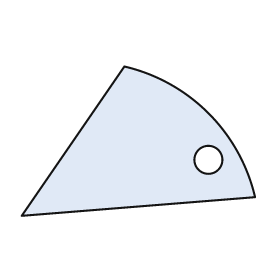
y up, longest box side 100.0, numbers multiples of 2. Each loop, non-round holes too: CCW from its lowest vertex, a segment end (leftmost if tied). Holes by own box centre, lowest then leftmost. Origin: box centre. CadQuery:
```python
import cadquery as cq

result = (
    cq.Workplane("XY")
    .moveTo(-50.0, -32.0)
    .lineTo(50.0, -24.0)
    .threePointArc((30.0, 12.0), (-6.0, 32.0))
    .close()
    .moveTo(30.0, -8.0)
    .circle(6.0)
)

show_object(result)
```